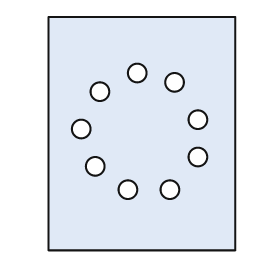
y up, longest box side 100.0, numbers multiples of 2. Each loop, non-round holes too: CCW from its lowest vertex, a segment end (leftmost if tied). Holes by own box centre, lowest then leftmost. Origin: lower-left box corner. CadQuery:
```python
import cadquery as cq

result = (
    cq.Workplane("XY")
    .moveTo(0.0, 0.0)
    .lineTo(80.0, 0.0)
    .lineTo(80.0, 100.0)
    .lineTo(0.0, 100.0)
    .close()
    .moveTo(34.0, 26.0)
    .circle(4.0)
    .moveTo(52.0, 26.0)
    .circle(4.0)
    .moveTo(20.0, 36.0)
    .circle(4.0)
    .moveTo(64.0, 40.0)
    .circle(4.0)
    .moveTo(14.0, 52.0)
    .circle(4.0)
    .moveTo(64.0, 56.0)
    .circle(4.0)
    .moveTo(22.0, 68.0)
    .circle(4.0)
    .moveTo(54.0, 72.0)
    .circle(4.0)
    .moveTo(38.0, 76.0)
    .circle(4.0)
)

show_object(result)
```